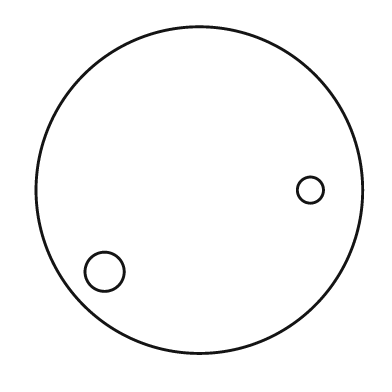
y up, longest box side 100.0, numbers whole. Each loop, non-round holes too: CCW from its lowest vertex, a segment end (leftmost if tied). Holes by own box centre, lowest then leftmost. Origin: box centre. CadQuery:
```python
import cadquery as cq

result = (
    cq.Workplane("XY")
    .moveTo(0.0, 0.0)
    .circle(50.0)
    .moveTo(-29.0, -25.0)
    .circle(6.0)
    .moveTo(34.0, 0.0)
    .circle(4.0)
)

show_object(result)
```